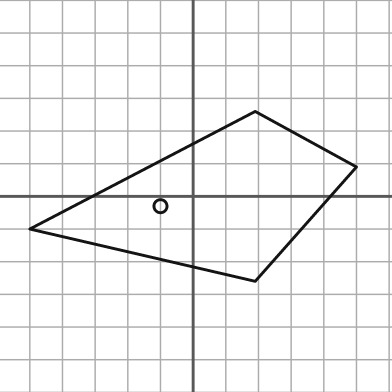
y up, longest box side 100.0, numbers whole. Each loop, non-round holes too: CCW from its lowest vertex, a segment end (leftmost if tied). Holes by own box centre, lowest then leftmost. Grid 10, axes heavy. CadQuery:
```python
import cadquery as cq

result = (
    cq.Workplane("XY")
    .moveTo(19.0, -26.0)
    .lineTo(50.0, 9.0)
    .lineTo(19.0, 26.0)
    .lineTo(-50.0, -10.0)
    .close()
    .moveTo(-10.0, -3.0)
    .circle(2.0)
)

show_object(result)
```